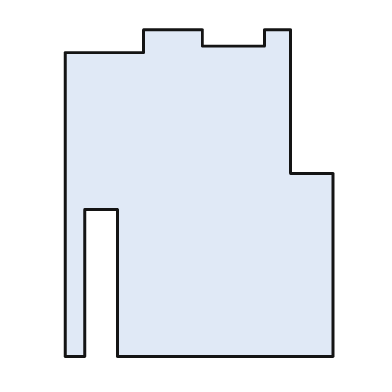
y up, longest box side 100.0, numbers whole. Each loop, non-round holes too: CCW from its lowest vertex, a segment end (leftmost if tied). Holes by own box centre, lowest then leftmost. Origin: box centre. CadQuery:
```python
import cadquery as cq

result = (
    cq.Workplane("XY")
    .moveTo(-41.0, -50.0)
    .lineTo(-35.0, -50.0)
    .lineTo(-35.0, -5.0)
    .lineTo(-25.0, -5.0)
    .lineTo(-25.0, -50.0)
    .lineTo(41.0, -50.0)
    .lineTo(41.0, 6.0)
    .lineTo(28.0, 6.0)
    .lineTo(28.0, 50.0)
    .lineTo(20.0, 50.0)
    .lineTo(20.0, 45.0)
    .lineTo(1.0, 45.0)
    .lineTo(1.0, 50.0)
    .lineTo(-17.0, 50.0)
    .lineTo(-17.0, 43.0)
    .lineTo(-41.0, 43.0)
    .close()
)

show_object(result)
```